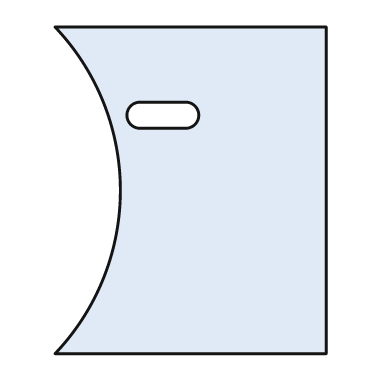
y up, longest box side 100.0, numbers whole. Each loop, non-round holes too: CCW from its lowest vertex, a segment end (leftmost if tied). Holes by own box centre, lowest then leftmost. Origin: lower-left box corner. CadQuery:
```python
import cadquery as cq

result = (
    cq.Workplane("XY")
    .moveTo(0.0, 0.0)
    .lineTo(83.0, 0.0)
    .lineTo(83.0, 100.0)
    .lineTo(0.0, 100.0)
    .threePointArc((20.0, 50.0), (0.0, 0.0))
    .close()
    .moveTo(26.0, 69.0)
    .lineTo(40.0, 69.0)
    .threePointArc((44.0, 73.0), (40.0, 77.0))
    .lineTo(26.0, 77.0)
    .threePointArc((22.0, 73.0), (26.0, 69.0))
    .close()
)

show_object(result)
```